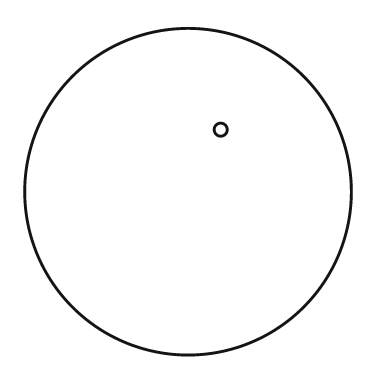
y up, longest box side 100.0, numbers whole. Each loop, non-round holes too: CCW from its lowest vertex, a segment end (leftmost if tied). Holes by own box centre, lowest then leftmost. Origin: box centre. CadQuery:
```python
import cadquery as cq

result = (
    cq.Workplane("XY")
    .moveTo(0.0, 0.0)
    .circle(50.0)
    .moveTo(10.0, 19.0)
    .circle(2.0)
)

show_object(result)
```